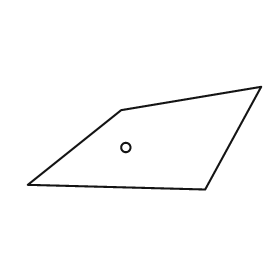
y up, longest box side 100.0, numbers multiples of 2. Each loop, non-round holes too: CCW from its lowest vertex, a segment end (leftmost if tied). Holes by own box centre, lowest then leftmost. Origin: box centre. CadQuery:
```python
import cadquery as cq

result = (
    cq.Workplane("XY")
    .moveTo(26.0, -22.0)
    .lineTo(50.0, 22.0)
    .lineTo(-10.0, 12.0)
    .lineTo(-50.0, -20.0)
    .close()
    .moveTo(-8.0, -4.0)
    .circle(2.0)
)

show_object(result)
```